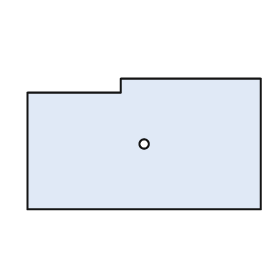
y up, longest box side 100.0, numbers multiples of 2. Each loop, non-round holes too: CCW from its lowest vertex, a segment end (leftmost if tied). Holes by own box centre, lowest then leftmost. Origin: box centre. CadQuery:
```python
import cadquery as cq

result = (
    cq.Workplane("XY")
    .moveTo(-50.0, -28.0)
    .lineTo(50.0, -28.0)
    .lineTo(50.0, 28.0)
    .lineTo(-10.0, 28.0)
    .lineTo(-10.0, 22.0)
    .lineTo(-50.0, 22.0)
    .close()
    .moveTo(0.0, 0.0)
    .circle(2.0)
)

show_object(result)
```